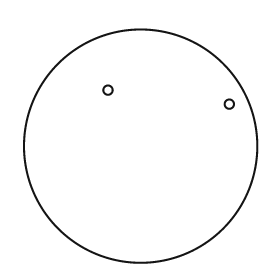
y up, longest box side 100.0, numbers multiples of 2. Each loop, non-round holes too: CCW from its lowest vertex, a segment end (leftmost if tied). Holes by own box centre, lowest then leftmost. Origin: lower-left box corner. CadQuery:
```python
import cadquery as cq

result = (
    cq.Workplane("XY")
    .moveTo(50.0, 50.0)
    .circle(50.0)
    .moveTo(88.0, 68.0)
    .circle(2.0)
    .moveTo(36.0, 74.0)
    .circle(2.0)
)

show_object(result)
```